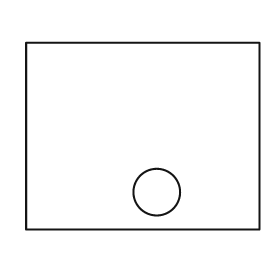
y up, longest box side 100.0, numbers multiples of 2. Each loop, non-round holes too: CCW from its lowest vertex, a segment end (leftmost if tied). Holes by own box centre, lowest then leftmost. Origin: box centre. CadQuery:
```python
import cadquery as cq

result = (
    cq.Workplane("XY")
    .moveTo(-50.0, -40.0)
    .lineTo(50.0, -40.0)
    .lineTo(50.0, 40.0)
    .lineTo(-50.0, 40.0)
    .close()
    .moveTo(6.0, -24.0)
    .circle(10.0)
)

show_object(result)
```